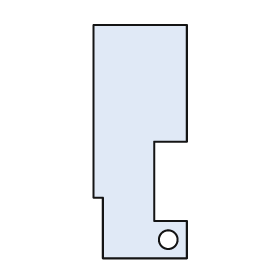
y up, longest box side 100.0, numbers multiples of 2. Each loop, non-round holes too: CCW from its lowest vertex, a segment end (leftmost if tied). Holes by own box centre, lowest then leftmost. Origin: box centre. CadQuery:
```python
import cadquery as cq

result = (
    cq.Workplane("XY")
    .moveTo(-16.0, -50.0)
    .lineTo(20.0, -50.0)
    .lineTo(20.0, -34.0)
    .lineTo(6.0, -34.0)
    .lineTo(6.0, 0.0)
    .lineTo(20.0, 0.0)
    .lineTo(20.0, 50.0)
    .lineTo(-20.0, 50.0)
    .lineTo(-20.0, -24.0)
    .lineTo(-16.0, -24.0)
    .close()
    .moveTo(12.0, -42.0)
    .circle(4.0)
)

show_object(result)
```